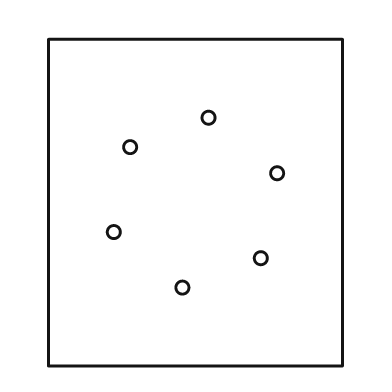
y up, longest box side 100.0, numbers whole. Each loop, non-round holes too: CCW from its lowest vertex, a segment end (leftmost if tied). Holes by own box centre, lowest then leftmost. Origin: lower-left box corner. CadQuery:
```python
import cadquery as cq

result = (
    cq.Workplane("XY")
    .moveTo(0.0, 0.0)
    .lineTo(90.0, 0.0)
    .lineTo(90.0, 100.0)
    .lineTo(0.0, 100.0)
    .close()
    .moveTo(41.0, 24.0)
    .circle(2.0)
    .moveTo(65.0, 33.0)
    .circle(2.0)
    .moveTo(20.0, 41.0)
    .circle(2.0)
    .moveTo(70.0, 59.0)
    .circle(2.0)
    .moveTo(25.0, 67.0)
    .circle(2.0)
    .moveTo(49.0, 76.0)
    .circle(2.0)
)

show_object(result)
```